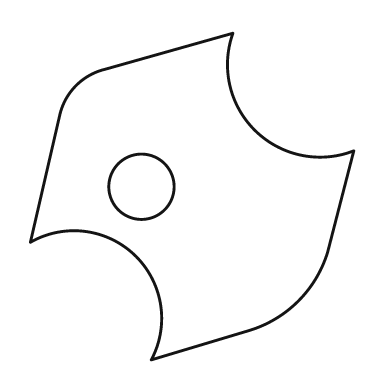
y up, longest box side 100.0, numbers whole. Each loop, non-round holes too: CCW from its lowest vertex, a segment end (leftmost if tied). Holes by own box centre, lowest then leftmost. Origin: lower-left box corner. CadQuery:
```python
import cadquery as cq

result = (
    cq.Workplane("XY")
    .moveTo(37.0, 0.0)
    .lineTo(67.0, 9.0)
    .threePointArc((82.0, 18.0), (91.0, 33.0))
    .lineTo(99.0, 64.0)
    .threePointArc((69.0, 70.0), (62.0, 100.0))
    .lineTo(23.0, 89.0)
    .threePointArc((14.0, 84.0), (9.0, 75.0))
    .lineTo(0.0, 36.0)
    .threePointArc((32.0, 32.0), (37.0, 0.0))
    .close()
    .moveTo(34.0, 53.0)
    .circle(10.0)
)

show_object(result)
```